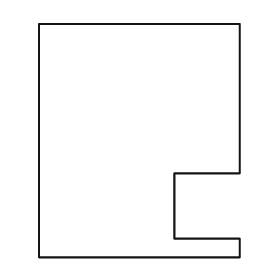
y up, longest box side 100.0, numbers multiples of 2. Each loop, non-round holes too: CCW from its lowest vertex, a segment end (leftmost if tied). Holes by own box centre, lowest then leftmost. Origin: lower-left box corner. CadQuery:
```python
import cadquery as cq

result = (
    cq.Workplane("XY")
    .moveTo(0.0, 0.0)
    .lineTo(86.0, 0.0)
    .lineTo(86.0, 8.0)
    .lineTo(58.0, 8.0)
    .lineTo(58.0, 36.0)
    .lineTo(86.0, 36.0)
    .lineTo(86.0, 100.0)
    .lineTo(0.0, 100.0)
    .close()
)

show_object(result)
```